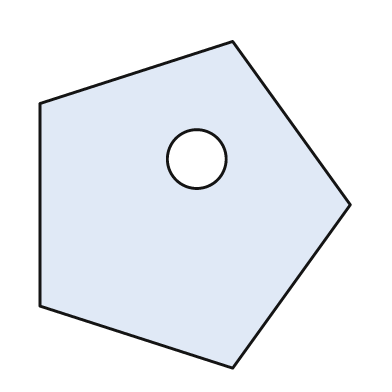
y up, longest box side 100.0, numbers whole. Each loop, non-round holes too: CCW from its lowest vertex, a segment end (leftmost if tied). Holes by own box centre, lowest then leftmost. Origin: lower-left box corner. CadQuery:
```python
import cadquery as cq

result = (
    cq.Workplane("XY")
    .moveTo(59.0, 0.0)
    .lineTo(95.0, 50.0)
    .lineTo(59.0, 100.0)
    .lineTo(0.0, 81.0)
    .lineTo(0.0, 19.0)
    .close()
    .moveTo(48.0, 64.0)
    .circle(9.0)
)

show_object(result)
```